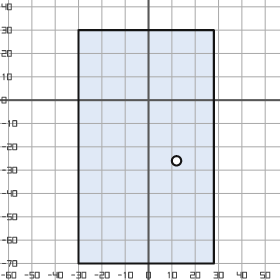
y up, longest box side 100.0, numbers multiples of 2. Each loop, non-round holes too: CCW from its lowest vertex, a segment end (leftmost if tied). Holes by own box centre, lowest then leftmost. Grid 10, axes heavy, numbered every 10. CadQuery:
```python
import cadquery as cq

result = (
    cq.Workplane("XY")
    .moveTo(-30.0, -70.0)
    .lineTo(28.0, -70.0)
    .lineTo(28.0, 30.0)
    .lineTo(-30.0, 30.0)
    .close()
    .moveTo(12.0, -26.0)
    .circle(2.0)
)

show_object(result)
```